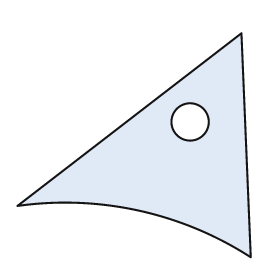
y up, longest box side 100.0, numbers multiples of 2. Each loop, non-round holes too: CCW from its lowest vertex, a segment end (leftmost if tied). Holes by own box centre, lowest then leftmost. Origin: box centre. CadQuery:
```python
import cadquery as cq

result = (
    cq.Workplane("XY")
    .moveTo(50.0, -48.0)
    .lineTo(46.0, 48.0)
    .lineTo(-50.0, -26.0)
    .threePointArc((2.0, -28.0), (50.0, -48.0))
    .close()
    .moveTo(24.0, 10.0)
    .circle(8.0)
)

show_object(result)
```